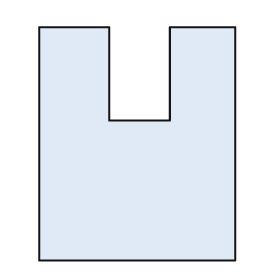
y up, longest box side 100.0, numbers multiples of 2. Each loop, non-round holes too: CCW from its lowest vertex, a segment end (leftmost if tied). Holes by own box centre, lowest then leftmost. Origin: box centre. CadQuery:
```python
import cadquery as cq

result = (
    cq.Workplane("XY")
    .moveTo(-42.0, -50.0)
    .lineTo(42.0, -50.0)
    .lineTo(42.0, 50.0)
    .lineTo(14.0, 50.0)
    .lineTo(14.0, 10.0)
    .lineTo(-12.0, 10.0)
    .lineTo(-12.0, 50.0)
    .lineTo(-42.0, 50.0)
    .close()
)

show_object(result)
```